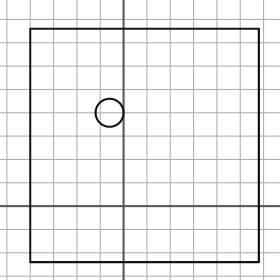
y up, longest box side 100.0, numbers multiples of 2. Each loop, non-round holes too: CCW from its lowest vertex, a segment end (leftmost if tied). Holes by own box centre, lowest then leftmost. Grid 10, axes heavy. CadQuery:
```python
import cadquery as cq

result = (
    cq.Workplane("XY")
    .moveTo(-40.0, -24.0)
    .lineTo(58.0, -24.0)
    .lineTo(58.0, 76.0)
    .lineTo(-40.0, 76.0)
    .close()
    .moveTo(-6.0, 40.0)
    .circle(6.0)
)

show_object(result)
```